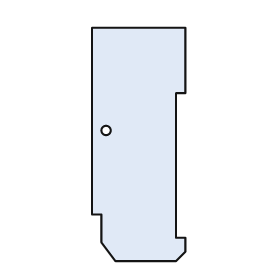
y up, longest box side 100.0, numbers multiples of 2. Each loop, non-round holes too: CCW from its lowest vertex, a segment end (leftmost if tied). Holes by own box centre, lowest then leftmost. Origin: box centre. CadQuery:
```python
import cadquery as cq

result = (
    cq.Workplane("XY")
    .moveTo(-10.0, -50.0)
    .lineTo(16.0, -50.0)
    .lineTo(20.0, -46.0)
    .lineTo(20.0, -40.0)
    .lineTo(16.0, -40.0)
    .lineTo(16.0, 22.0)
    .lineTo(20.0, 22.0)
    .lineTo(20.0, 50.0)
    .lineTo(-20.0, 50.0)
    .lineTo(-20.0, -30.0)
    .lineTo(-16.0, -30.0)
    .lineTo(-16.0, -42.0)
    .close()
    .moveTo(-14.0, 6.0)
    .circle(2.0)
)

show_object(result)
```